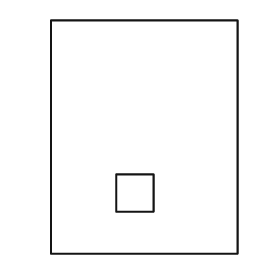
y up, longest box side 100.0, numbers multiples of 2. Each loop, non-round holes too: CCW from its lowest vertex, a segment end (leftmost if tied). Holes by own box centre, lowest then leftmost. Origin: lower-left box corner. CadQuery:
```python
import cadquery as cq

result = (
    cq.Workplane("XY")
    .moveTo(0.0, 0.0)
    .lineTo(80.0, 0.0)
    .lineTo(80.0, 100.0)
    .lineTo(0.0, 100.0)
    .close()
    .moveTo(28.0, 18.0)
    .lineTo(44.0, 18.0)
    .lineTo(44.0, 34.0)
    .lineTo(28.0, 34.0)
    .close()
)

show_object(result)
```